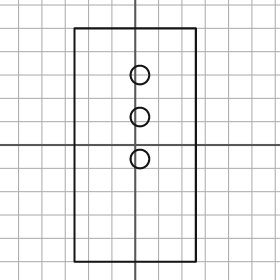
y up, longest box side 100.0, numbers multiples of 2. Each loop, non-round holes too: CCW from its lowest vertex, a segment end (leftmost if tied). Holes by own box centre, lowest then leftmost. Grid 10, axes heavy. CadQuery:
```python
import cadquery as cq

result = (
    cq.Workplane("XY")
    .moveTo(-26.0, -50.0)
    .lineTo(26.0, -50.0)
    .lineTo(26.0, 50.0)
    .lineTo(-26.0, 50.0)
    .close()
    .moveTo(2.0, -6.0)
    .circle(4.0)
    .moveTo(2.0, 12.0)
    .circle(4.0)
    .moveTo(2.0, 30.0)
    .circle(4.0)
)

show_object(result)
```